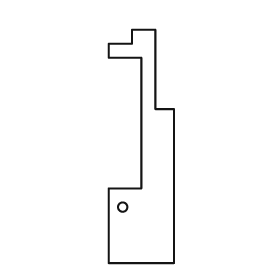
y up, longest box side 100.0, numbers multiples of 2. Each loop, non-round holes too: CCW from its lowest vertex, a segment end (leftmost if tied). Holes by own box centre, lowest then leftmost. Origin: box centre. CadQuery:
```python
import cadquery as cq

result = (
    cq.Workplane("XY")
    .moveTo(-14.0, -50.0)
    .lineTo(14.0, -50.0)
    .lineTo(14.0, 16.0)
    .lineTo(6.0, 16.0)
    .lineTo(6.0, 50.0)
    .lineTo(-4.0, 50.0)
    .lineTo(-4.0, 44.0)
    .lineTo(-14.0, 44.0)
    .lineTo(-14.0, 38.0)
    .lineTo(0.0, 38.0)
    .lineTo(0.0, -18.0)
    .lineTo(-14.0, -18.0)
    .close()
    .moveTo(-8.0, -26.0)
    .circle(2.0)
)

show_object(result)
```